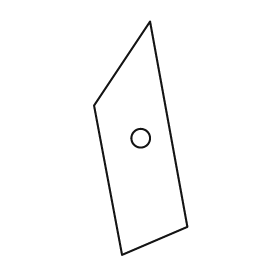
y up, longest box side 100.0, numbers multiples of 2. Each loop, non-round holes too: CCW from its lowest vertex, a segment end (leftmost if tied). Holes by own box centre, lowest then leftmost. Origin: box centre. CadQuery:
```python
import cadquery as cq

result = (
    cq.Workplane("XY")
    .moveTo(-8.0, -50.0)
    .lineTo(20.0, -38.0)
    .lineTo(4.0, 50.0)
    .lineTo(-20.0, 14.0)
    .close()
    .moveTo(0.0, 0.0)
    .circle(4.0)
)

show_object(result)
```